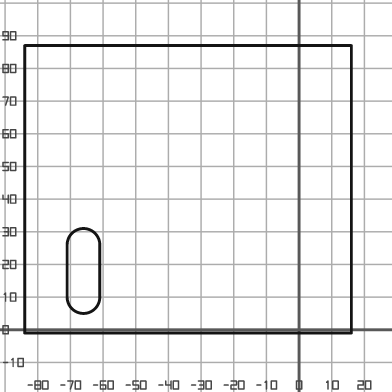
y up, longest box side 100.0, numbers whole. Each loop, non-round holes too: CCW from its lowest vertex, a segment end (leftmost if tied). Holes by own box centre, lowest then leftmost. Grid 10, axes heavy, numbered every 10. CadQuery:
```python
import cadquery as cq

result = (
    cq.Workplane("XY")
    .moveTo(-84.0, -1.0)
    .lineTo(16.0, -1.0)
    .lineTo(16.0, 87.0)
    .lineTo(-84.0, 87.0)
    .close()
    .moveTo(-71.0, 10.0)
    .threePointArc((-66.0, 5.0), (-61.0, 10.0))
    .lineTo(-61.0, 26.0)
    .threePointArc((-66.0, 31.0), (-71.0, 26.0))
    .close()
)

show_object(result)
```